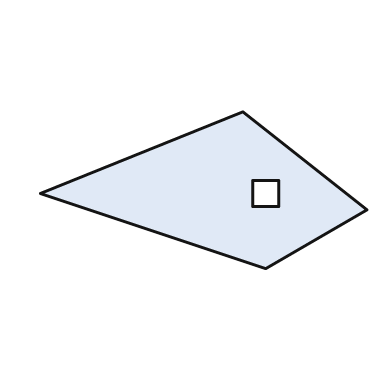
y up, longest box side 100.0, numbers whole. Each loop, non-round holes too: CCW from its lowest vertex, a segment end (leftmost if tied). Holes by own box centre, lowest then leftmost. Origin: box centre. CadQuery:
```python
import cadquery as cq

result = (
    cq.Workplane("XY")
    .moveTo(19.0, -24.0)
    .lineTo(50.0, -6.0)
    .lineTo(12.0, 24.0)
    .lineTo(-50.0, -1.0)
    .close()
    .moveTo(15.0, -5.0)
    .lineTo(23.0, -5.0)
    .lineTo(23.0, 3.0)
    .lineTo(15.0, 3.0)
    .close()
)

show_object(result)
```